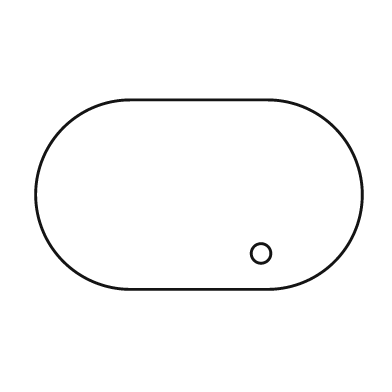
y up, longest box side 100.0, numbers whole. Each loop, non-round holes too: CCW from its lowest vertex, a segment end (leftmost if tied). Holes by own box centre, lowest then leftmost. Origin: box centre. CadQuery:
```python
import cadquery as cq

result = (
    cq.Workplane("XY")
    .moveTo(-21.0, -29.0)
    .lineTo(21.0, -29.0)
    .threePointArc((50.0, 0.0), (21.0, 29.0))
    .lineTo(-21.0, 29.0)
    .threePointArc((-50.0, 0.0), (-21.0, -29.0))
    .close()
    .moveTo(19.0, -18.0)
    .circle(3.0)
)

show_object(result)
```